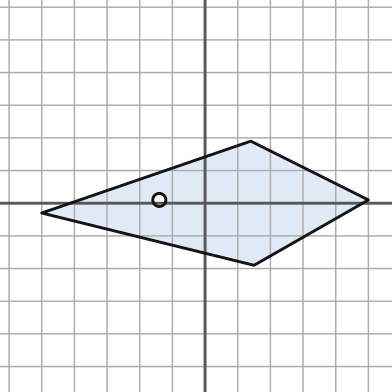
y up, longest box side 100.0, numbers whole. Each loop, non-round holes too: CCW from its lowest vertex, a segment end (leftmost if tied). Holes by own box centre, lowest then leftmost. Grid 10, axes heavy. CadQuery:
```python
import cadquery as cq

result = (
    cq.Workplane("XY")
    .moveTo(15.0, -19.0)
    .lineTo(50.0, 1.0)
    .lineTo(14.0, 19.0)
    .lineTo(-50.0, -3.0)
    .close()
    .moveTo(-14.0, 1.0)
    .circle(2.0)
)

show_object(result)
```